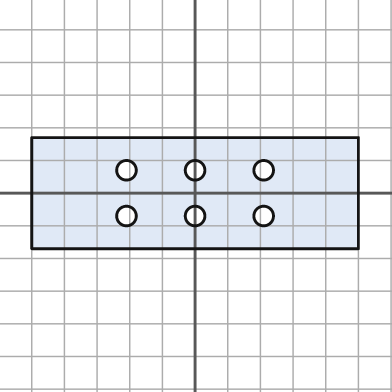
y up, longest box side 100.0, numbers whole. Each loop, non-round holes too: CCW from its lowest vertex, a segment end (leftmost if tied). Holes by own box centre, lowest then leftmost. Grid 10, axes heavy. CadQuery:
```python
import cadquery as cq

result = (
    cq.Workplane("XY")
    .moveTo(-50.0, -17.0)
    .lineTo(50.0, -17.0)
    .lineTo(50.0, 17.0)
    .lineTo(-50.0, 17.0)
    .close()
    .moveTo(-21.0, -7.0)
    .circle(3.0)
    .moveTo(0.0, -7.0)
    .circle(3.0)
    .moveTo(21.0, -7.0)
    .circle(3.0)
    .moveTo(-21.0, 7.0)
    .circle(3.0)
    .moveTo(0.0, 7.0)
    .circle(3.0)
    .moveTo(21.0, 7.0)
    .circle(3.0)
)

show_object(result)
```